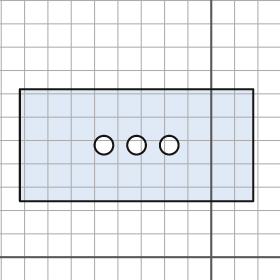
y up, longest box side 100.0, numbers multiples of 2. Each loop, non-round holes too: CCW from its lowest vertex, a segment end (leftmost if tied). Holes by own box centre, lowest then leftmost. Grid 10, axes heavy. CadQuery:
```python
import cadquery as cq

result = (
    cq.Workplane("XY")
    .moveTo(-82.0, 24.0)
    .lineTo(18.0, 24.0)
    .lineTo(18.0, 72.0)
    .lineTo(-82.0, 72.0)
    .close()
    .moveTo(-46.0, 48.0)
    .circle(4.0)
    .moveTo(-32.0, 48.0)
    .circle(4.0)
    .moveTo(-18.0, 48.0)
    .circle(4.0)
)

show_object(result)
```